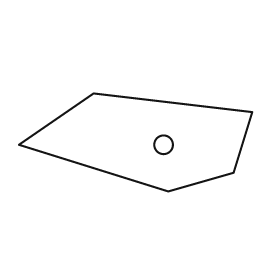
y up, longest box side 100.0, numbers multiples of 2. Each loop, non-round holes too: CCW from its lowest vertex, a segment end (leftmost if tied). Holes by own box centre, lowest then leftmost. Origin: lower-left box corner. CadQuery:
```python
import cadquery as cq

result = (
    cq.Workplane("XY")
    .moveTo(64.0, 0.0)
    .lineTo(92.0, 8.0)
    .lineTo(100.0, 34.0)
    .lineTo(32.0, 42.0)
    .lineTo(0.0, 20.0)
    .close()
    .moveTo(62.0, 20.0)
    .circle(4.0)
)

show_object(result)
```